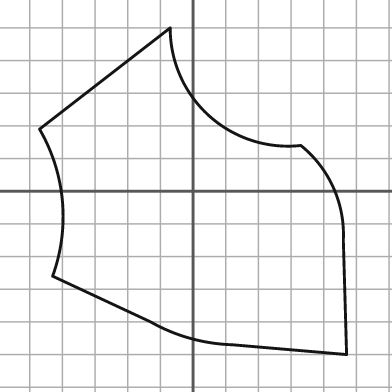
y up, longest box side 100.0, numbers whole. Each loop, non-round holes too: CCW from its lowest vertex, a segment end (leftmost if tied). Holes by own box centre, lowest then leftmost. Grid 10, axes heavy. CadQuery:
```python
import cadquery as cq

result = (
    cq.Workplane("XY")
    .moveTo(47.0, -50.0)
    .lineTo(46.0, -15.0)
    .threePointArc((43.0, 1.0), (33.0, 14.0))
    .threePointArc((5.0, 23.0), (-7.0, 50.0))
    .lineTo(-47.0, 19.0)
    .threePointArc((-40.0, -3.0), (-43.0, -26.0))
    .lineTo(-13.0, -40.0)
    .threePointArc((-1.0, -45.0), (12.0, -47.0))
    .close()
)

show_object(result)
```